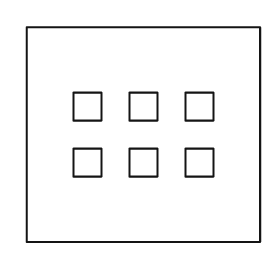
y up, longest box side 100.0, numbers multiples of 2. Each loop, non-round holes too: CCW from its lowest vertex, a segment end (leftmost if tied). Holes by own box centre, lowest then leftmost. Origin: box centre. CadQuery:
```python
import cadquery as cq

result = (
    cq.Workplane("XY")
    .moveTo(-50.0, -46.0)
    .lineTo(50.0, -46.0)
    .lineTo(50.0, 46.0)
    .lineTo(-50.0, 46.0)
    .close()
    .moveTo(-30.0, -18.0)
    .lineTo(-18.0, -18.0)
    .lineTo(-18.0, -6.0)
    .lineTo(-30.0, -6.0)
    .close()
    .moveTo(-6.0, -18.0)
    .lineTo(6.0, -18.0)
    .lineTo(6.0, -6.0)
    .lineTo(-6.0, -6.0)
    .close()
    .moveTo(18.0, -18.0)
    .lineTo(30.0, -18.0)
    .lineTo(30.0, -6.0)
    .lineTo(18.0, -6.0)
    .close()
    .moveTo(-30.0, 6.0)
    .lineTo(-18.0, 6.0)
    .lineTo(-18.0, 18.0)
    .lineTo(-30.0, 18.0)
    .close()
    .moveTo(-6.0, 6.0)
    .lineTo(6.0, 6.0)
    .lineTo(6.0, 18.0)
    .lineTo(-6.0, 18.0)
    .close()
    .moveTo(18.0, 6.0)
    .lineTo(30.0, 6.0)
    .lineTo(30.0, 18.0)
    .lineTo(18.0, 18.0)
    .close()
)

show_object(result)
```